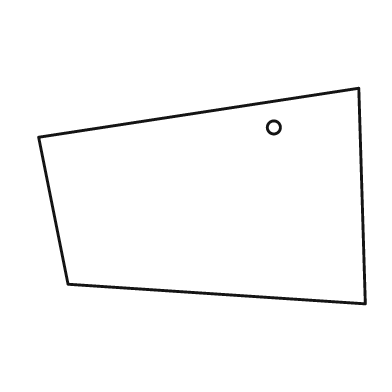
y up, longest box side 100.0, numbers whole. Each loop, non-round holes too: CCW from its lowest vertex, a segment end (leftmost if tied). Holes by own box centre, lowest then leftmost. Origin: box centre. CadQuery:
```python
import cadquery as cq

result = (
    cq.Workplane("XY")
    .moveTo(50.0, -33.0)
    .lineTo(48.0, 33.0)
    .lineTo(-50.0, 18.0)
    .lineTo(-41.0, -27.0)
    .close()
    .moveTo(22.0, 21.0)
    .circle(2.0)
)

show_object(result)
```